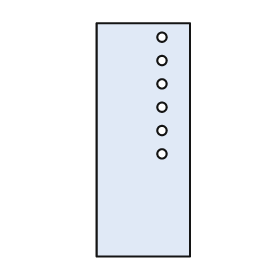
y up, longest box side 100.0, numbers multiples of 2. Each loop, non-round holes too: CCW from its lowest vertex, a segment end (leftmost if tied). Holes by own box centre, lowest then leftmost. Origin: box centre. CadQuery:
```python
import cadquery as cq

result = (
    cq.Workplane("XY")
    .moveTo(-20.0, -50.0)
    .lineTo(20.0, -50.0)
    .lineTo(20.0, 50.0)
    .lineTo(-20.0, 50.0)
    .close()
    .moveTo(8.0, -6.0)
    .circle(2.0)
    .moveTo(8.0, 4.0)
    .circle(2.0)
    .moveTo(8.0, 14.0)
    .circle(2.0)
    .moveTo(8.0, 24.0)
    .circle(2.0)
    .moveTo(8.0, 34.0)
    .circle(2.0)
    .moveTo(8.0, 44.0)
    .circle(2.0)
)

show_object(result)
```